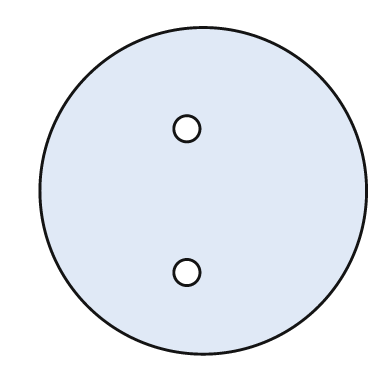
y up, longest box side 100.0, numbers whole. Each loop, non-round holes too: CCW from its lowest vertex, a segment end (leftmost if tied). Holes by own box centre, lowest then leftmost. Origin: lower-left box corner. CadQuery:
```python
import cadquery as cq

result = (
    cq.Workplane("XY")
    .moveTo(50.0, 50.0)
    .circle(50.0)
    .moveTo(45.0, 25.0)
    .circle(4.0)
    .moveTo(45.0, 69.0)
    .circle(4.0)
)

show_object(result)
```